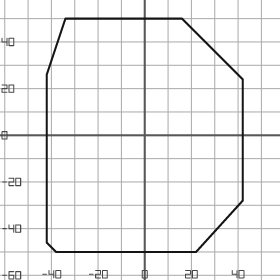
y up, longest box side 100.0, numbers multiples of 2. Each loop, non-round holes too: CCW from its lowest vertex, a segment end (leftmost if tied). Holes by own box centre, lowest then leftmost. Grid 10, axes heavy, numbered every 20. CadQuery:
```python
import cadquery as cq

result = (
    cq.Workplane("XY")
    .moveTo(-38.0, -50.0)
    .lineTo(22.0, -50.0)
    .lineTo(42.0, -28.0)
    .lineTo(42.0, 24.0)
    .lineTo(16.0, 50.0)
    .lineTo(-34.0, 50.0)
    .lineTo(-42.0, 26.0)
    .lineTo(-42.0, -46.0)
    .close()
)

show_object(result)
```